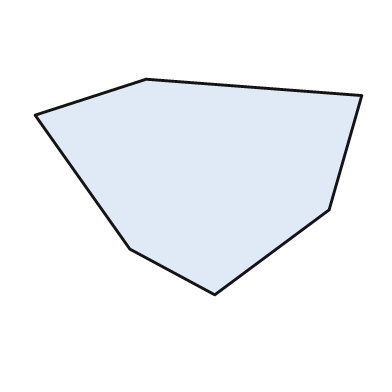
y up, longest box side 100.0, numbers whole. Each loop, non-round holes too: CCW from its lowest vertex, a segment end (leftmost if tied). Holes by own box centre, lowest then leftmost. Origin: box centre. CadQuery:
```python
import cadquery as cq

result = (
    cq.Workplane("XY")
    .moveTo(5.0, -33.0)
    .lineTo(40.0, -7.0)
    .lineTo(50.0, 28.0)
    .lineTo(-16.0, 33.0)
    .lineTo(-50.0, 22.0)
    .lineTo(-21.0, -19.0)
    .close()
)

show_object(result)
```